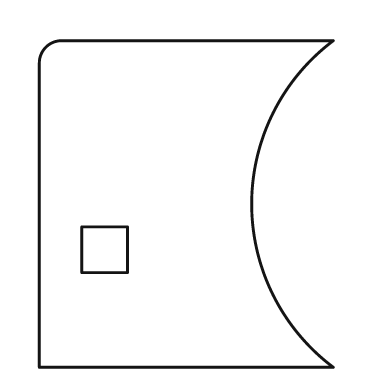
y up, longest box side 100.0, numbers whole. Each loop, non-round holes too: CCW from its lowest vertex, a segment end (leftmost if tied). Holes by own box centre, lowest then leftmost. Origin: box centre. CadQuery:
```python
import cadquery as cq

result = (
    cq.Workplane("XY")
    .moveTo(-45.0, -50.0)
    .lineTo(45.0, -50.0)
    .threePointArc((20.0, 0.0), (45.0, 50.0))
    .lineTo(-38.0, 50.0)
    .threePointArc((-43.0, 48.0), (-45.0, 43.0))
    .close()
    .moveTo(-32.0, -21.0)
    .lineTo(-18.0, -21.0)
    .lineTo(-18.0, -7.0)
    .lineTo(-32.0, -7.0)
    .close()
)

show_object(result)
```